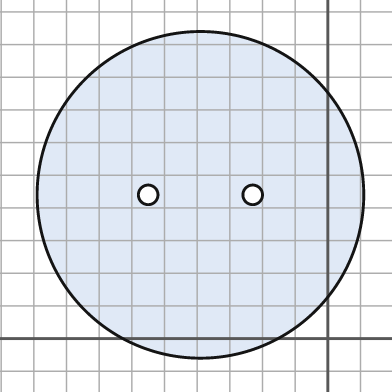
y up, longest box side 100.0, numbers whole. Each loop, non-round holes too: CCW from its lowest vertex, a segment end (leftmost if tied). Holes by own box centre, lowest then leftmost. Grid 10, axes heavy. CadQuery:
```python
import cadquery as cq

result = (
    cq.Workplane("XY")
    .moveTo(-39.0, 44.0)
    .circle(50.0)
    .moveTo(-55.0, 44.0)
    .circle(3.0)
    .moveTo(-23.0, 44.0)
    .circle(3.0)
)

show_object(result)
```